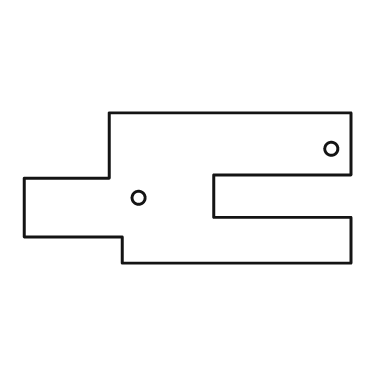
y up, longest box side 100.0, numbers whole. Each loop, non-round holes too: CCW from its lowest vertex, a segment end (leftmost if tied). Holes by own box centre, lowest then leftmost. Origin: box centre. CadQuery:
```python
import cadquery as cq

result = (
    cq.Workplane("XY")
    .moveTo(-20.0, -23.0)
    .lineTo(50.0, -23.0)
    .lineTo(50.0, -9.0)
    .lineTo(8.0, -9.0)
    .lineTo(8.0, 4.0)
    .lineTo(50.0, 4.0)
    .lineTo(50.0, 23.0)
    .lineTo(-24.0, 23.0)
    .lineTo(-24.0, 3.0)
    .lineTo(-50.0, 3.0)
    .lineTo(-50.0, -15.0)
    .lineTo(-20.0, -15.0)
    .close()
    .moveTo(-15.0, -3.0)
    .circle(2.0)
    .moveTo(44.0, 12.0)
    .circle(2.0)
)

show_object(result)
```